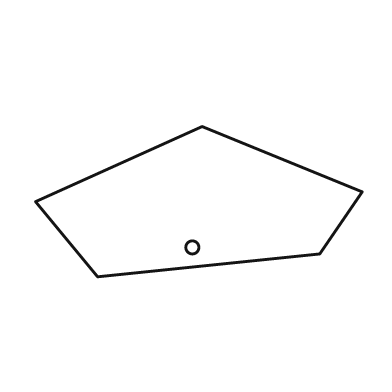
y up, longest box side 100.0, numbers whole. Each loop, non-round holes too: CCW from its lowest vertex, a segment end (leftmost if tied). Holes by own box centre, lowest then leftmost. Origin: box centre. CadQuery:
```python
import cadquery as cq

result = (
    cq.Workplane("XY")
    .moveTo(-31.0, -23.0)
    .lineTo(37.0, -16.0)
    .lineTo(50.0, 3.0)
    .lineTo(1.0, 23.0)
    .lineTo(-50.0, 0.0)
    .close()
    .moveTo(-2.0, -14.0)
    .circle(2.0)
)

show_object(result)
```